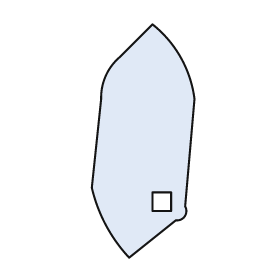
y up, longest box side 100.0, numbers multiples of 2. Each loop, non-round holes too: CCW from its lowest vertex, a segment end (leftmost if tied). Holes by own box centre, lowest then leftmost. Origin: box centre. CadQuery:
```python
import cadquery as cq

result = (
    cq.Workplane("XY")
    .moveTo(-6.0, -50.0)
    .lineTo(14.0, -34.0)
    .threePointArc((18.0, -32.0), (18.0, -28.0))
    .lineTo(22.0, 18.0)
    .threePointArc((16.0, 36.0), (4.0, 50.0))
    .lineTo(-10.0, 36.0)
    .threePointArc((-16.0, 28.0), (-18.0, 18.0))
    .lineTo(-22.0, -20.0)
    .threePointArc((-16.0, -36.0), (-6.0, -50.0))
    .close()
    .moveTo(4.0, -30.0)
    .lineTo(12.0, -30.0)
    .lineTo(12.0, -22.0)
    .lineTo(4.0, -22.0)
    .close()
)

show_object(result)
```